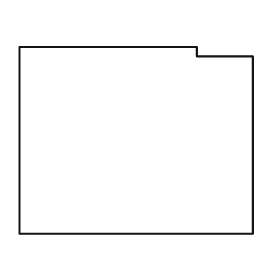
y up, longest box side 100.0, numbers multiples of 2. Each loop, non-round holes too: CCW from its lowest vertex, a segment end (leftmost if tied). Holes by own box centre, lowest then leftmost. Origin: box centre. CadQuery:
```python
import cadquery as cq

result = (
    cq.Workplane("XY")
    .moveTo(-50.0, -40.0)
    .lineTo(50.0, -40.0)
    .lineTo(50.0, 36.0)
    .lineTo(26.0, 36.0)
    .lineTo(26.0, 40.0)
    .lineTo(-50.0, 40.0)
    .close()
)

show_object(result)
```